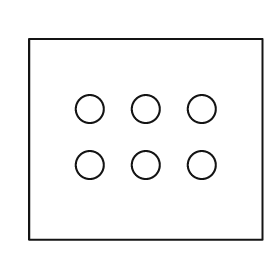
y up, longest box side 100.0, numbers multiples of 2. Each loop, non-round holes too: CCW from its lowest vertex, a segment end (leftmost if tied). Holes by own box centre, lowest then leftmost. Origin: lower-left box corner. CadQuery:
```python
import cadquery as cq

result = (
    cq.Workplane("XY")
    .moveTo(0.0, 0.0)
    .lineTo(100.0, 0.0)
    .lineTo(100.0, 86.0)
    .lineTo(0.0, 86.0)
    .close()
    .moveTo(26.0, 32.0)
    .circle(6.0)
    .moveTo(50.0, 32.0)
    .circle(6.0)
    .moveTo(74.0, 32.0)
    .circle(6.0)
    .moveTo(26.0, 56.0)
    .circle(6.0)
    .moveTo(50.0, 56.0)
    .circle(6.0)
    .moveTo(74.0, 56.0)
    .circle(6.0)
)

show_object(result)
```